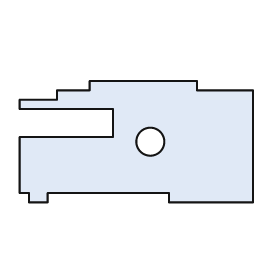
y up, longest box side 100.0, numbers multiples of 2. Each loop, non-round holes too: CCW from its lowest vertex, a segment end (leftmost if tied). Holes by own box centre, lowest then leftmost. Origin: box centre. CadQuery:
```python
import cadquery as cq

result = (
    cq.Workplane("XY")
    .moveTo(-46.0, -26.0)
    .lineTo(-38.0, -26.0)
    .lineTo(-38.0, -22.0)
    .lineTo(14.0, -22.0)
    .lineTo(14.0, -26.0)
    .lineTo(50.0, -26.0)
    .lineTo(50.0, 22.0)
    .lineTo(26.0, 22.0)
    .lineTo(26.0, 26.0)
    .lineTo(-20.0, 26.0)
    .lineTo(-20.0, 22.0)
    .lineTo(-34.0, 22.0)
    .lineTo(-34.0, 18.0)
    .lineTo(-50.0, 18.0)
    .lineTo(-50.0, 14.0)
    .lineTo(-10.0, 14.0)
    .lineTo(-10.0, 2.0)
    .lineTo(-50.0, 2.0)
    .lineTo(-50.0, -22.0)
    .lineTo(-46.0, -22.0)
    .close()
    .moveTo(6.0, 0.0)
    .circle(6.0)
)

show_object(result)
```